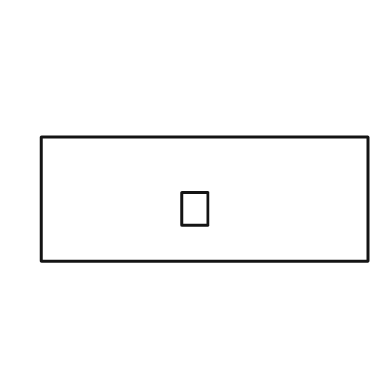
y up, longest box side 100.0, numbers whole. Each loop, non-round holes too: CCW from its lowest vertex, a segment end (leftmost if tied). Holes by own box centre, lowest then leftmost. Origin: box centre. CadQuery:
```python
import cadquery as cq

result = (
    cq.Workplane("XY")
    .moveTo(-50.0, -19.0)
    .lineTo(50.0, -19.0)
    .lineTo(50.0, 19.0)
    .lineTo(-50.0, 19.0)
    .close()
    .moveTo(-7.0, -8.0)
    .lineTo(1.0, -8.0)
    .lineTo(1.0, 2.0)
    .lineTo(-7.0, 2.0)
    .close()
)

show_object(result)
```